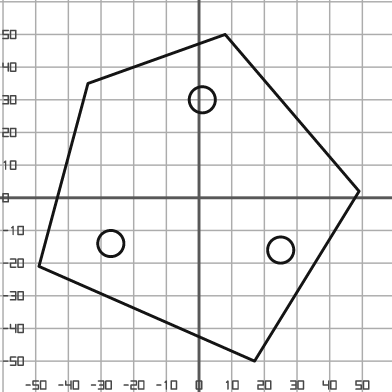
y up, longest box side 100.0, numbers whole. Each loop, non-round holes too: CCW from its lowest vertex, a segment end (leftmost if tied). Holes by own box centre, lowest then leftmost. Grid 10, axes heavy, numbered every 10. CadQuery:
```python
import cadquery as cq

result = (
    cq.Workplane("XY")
    .moveTo(17.0, -50.0)
    .lineTo(49.0, 2.0)
    .lineTo(8.0, 50.0)
    .lineTo(-34.0, 35.0)
    .lineTo(-49.0, -21.0)
    .close()
    .moveTo(25.0, -16.0)
    .circle(4.0)
    .moveTo(-27.0, -14.0)
    .circle(4.0)
    .moveTo(1.0, 30.0)
    .circle(4.0)
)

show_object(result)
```